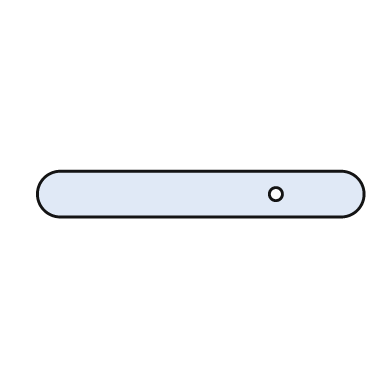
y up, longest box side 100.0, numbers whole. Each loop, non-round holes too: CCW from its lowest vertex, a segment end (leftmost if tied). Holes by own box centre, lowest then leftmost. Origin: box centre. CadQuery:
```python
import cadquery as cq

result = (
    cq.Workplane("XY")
    .moveTo(-43.0, -7.0)
    .lineTo(43.0, -7.0)
    .threePointArc((50.0, 0.0), (43.0, 7.0))
    .lineTo(-43.0, 7.0)
    .threePointArc((-50.0, 0.0), (-43.0, -7.0))
    .close()
    .moveTo(23.0, 0.0)
    .circle(2.0)
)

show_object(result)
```